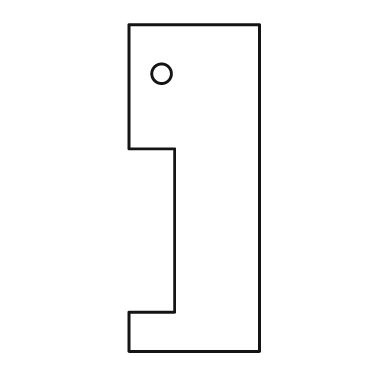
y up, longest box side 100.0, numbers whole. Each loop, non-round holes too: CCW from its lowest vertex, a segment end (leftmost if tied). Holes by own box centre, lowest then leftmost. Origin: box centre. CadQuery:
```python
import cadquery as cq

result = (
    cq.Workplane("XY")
    .moveTo(-20.0, -50.0)
    .lineTo(20.0, -50.0)
    .lineTo(20.0, 50.0)
    .lineTo(-20.0, 50.0)
    .lineTo(-20.0, 12.0)
    .lineTo(-6.0, 12.0)
    .lineTo(-6.0, -38.0)
    .lineTo(-20.0, -38.0)
    .close()
    .moveTo(-10.0, 35.0)
    .circle(3.0)
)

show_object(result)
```